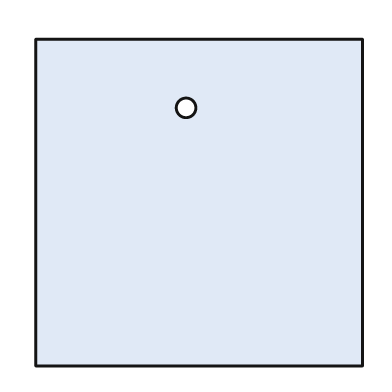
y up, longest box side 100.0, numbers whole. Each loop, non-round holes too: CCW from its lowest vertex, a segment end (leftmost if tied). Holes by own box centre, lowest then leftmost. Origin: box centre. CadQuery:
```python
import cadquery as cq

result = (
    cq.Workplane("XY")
    .moveTo(-50.0, -50.0)
    .lineTo(50.0, -50.0)
    .lineTo(50.0, 50.0)
    .lineTo(-50.0, 50.0)
    .close()
    .moveTo(-4.0, 29.0)
    .circle(3.0)
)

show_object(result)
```